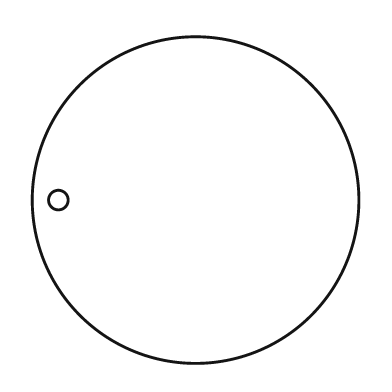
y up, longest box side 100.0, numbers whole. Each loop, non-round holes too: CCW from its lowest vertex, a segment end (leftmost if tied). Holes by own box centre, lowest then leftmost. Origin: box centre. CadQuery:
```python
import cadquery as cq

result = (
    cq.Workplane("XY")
    .moveTo(0.0, 0.0)
    .circle(50.0)
    .moveTo(-42.0, 0.0)
    .circle(3.0)
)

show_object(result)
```